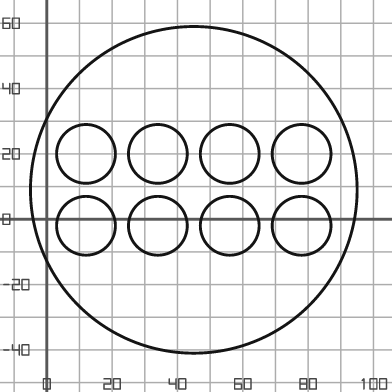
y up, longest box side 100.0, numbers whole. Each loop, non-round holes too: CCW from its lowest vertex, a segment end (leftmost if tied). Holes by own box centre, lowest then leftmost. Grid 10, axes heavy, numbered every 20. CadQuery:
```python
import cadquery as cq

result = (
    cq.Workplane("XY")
    .moveTo(45.0, 9.0)
    .circle(50.0)
    .moveTo(12.0, -2.0)
    .circle(9.0)
    .moveTo(34.0, -2.0)
    .circle(9.0)
    .moveTo(56.0, -2.0)
    .circle(9.0)
    .moveTo(78.0, -2.0)
    .circle(9.0)
    .moveTo(12.0, 20.0)
    .circle(9.0)
    .moveTo(34.0, 20.0)
    .circle(9.0)
    .moveTo(56.0, 20.0)
    .circle(9.0)
    .moveTo(78.0, 20.0)
    .circle(9.0)
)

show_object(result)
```